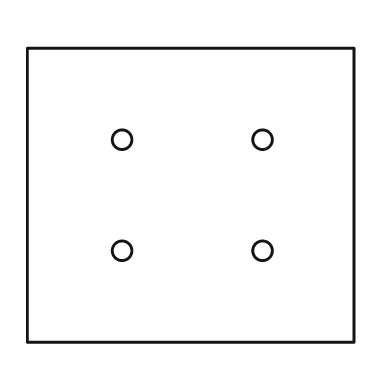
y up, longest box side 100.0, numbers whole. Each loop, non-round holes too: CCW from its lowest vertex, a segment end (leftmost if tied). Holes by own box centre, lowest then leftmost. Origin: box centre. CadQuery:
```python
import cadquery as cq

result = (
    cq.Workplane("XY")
    .moveTo(-50.0, -45.0)
    .lineTo(50.0, -45.0)
    .lineTo(50.0, 45.0)
    .lineTo(-50.0, 45.0)
    .close()
    .moveTo(-21.0, -17.0)
    .circle(3.0)
    .moveTo(22.0, -17.0)
    .circle(3.0)
    .moveTo(-21.0, 17.0)
    .circle(3.0)
    .moveTo(22.0, 17.0)
    .circle(3.0)
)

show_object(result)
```